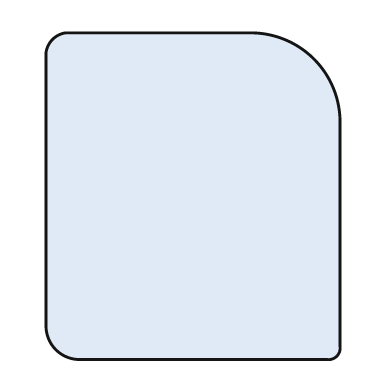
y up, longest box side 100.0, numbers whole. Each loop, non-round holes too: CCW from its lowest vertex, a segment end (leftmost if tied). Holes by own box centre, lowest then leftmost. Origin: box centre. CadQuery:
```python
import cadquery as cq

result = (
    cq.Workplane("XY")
    .moveTo(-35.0, -50.0)
    .lineTo(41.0, -50.0)
    .threePointArc((44.0, -49.0), (45.0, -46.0))
    .lineTo(45.0, 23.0)
    .threePointArc((37.0, 42.0), (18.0, 50.0))
    .lineTo(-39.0, 50.0)
    .threePointArc((-43.0, 48.0), (-45.0, 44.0))
    .lineTo(-45.0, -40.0)
    .threePointArc((-42.0, -47.0), (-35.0, -50.0))
    .close()
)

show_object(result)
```